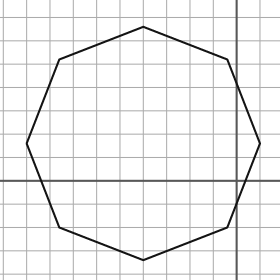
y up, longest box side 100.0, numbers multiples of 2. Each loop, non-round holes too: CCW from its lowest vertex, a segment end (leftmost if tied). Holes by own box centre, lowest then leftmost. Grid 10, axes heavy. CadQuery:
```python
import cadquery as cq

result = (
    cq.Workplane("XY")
    .moveTo(-40.0, -34.0)
    .lineTo(-4.0, -20.0)
    .lineTo(10.0, 16.0)
    .lineTo(-4.0, 52.0)
    .lineTo(-40.0, 66.0)
    .lineTo(-76.0, 52.0)
    .lineTo(-90.0, 16.0)
    .lineTo(-76.0, -20.0)
    .close()
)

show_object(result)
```